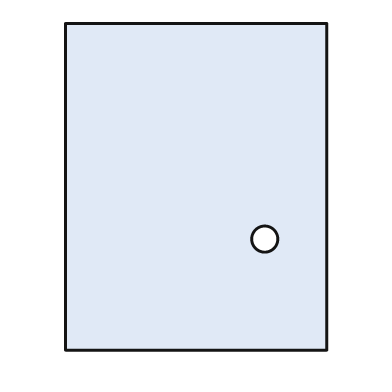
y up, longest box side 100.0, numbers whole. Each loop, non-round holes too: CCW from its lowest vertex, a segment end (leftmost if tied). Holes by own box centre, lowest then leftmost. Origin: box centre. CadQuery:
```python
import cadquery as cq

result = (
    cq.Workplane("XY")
    .moveTo(-40.0, -50.0)
    .lineTo(40.0, -50.0)
    .lineTo(40.0, 50.0)
    .lineTo(-40.0, 50.0)
    .close()
    .moveTo(21.0, -16.0)
    .circle(4.0)
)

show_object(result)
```